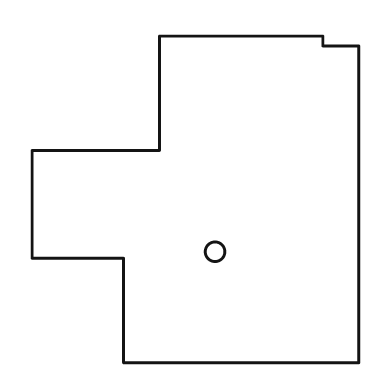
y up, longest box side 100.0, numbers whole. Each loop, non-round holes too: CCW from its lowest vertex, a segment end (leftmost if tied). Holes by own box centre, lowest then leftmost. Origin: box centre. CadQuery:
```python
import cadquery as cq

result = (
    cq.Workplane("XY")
    .moveTo(-22.0, -50.0)
    .lineTo(50.0, -50.0)
    .lineTo(50.0, 47.0)
    .lineTo(39.0, 47.0)
    .lineTo(39.0, 50.0)
    .lineTo(-11.0, 50.0)
    .lineTo(-11.0, 15.0)
    .lineTo(-50.0, 15.0)
    .lineTo(-50.0, -18.0)
    .lineTo(-22.0, -18.0)
    .close()
    .moveTo(6.0, -16.0)
    .circle(3.0)
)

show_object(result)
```